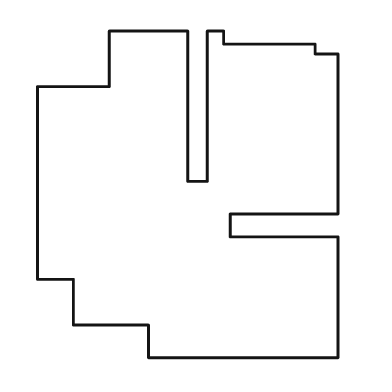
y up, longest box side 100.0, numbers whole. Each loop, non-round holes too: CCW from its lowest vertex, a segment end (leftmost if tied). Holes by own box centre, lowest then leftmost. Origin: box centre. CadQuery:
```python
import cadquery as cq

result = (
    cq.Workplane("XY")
    .moveTo(-12.0, -50.0)
    .lineTo(46.0, -50.0)
    .lineTo(46.0, -13.0)
    .lineTo(13.0, -13.0)
    .lineTo(13.0, -6.0)
    .lineTo(46.0, -6.0)
    .lineTo(46.0, 43.0)
    .lineTo(39.0, 43.0)
    .lineTo(39.0, 46.0)
    .lineTo(11.0, 46.0)
    .lineTo(11.0, 50.0)
    .lineTo(6.0, 50.0)
    .lineTo(6.0, 4.0)
    .lineTo(0.0, 4.0)
    .lineTo(0.0, 50.0)
    .lineTo(-24.0, 50.0)
    .lineTo(-24.0, 33.0)
    .lineTo(-46.0, 33.0)
    .lineTo(-46.0, -26.0)
    .lineTo(-35.0, -26.0)
    .lineTo(-35.0, -40.0)
    .lineTo(-12.0, -40.0)
    .close()
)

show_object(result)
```